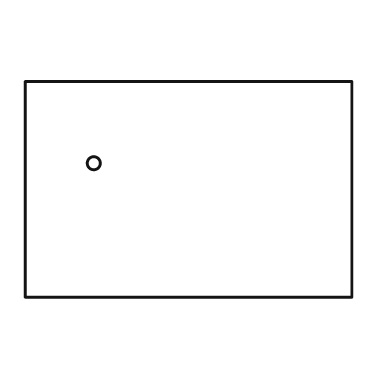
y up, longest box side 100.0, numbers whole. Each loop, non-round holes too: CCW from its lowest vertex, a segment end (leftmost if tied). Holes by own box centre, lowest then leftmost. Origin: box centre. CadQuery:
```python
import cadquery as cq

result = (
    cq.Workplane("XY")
    .moveTo(-50.0, -33.0)
    .lineTo(50.0, -33.0)
    .lineTo(50.0, 33.0)
    .lineTo(-50.0, 33.0)
    .close()
    .moveTo(-29.0, 8.0)
    .circle(2.0)
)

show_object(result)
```